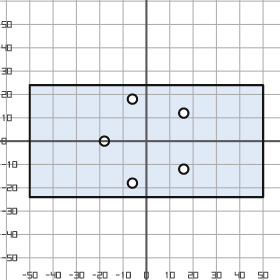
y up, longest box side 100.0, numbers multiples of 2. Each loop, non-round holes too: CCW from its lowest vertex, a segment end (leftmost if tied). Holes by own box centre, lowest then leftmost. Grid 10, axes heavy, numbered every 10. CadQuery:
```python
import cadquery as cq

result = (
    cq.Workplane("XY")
    .moveTo(-50.0, -24.0)
    .lineTo(50.0, -24.0)
    .lineTo(50.0, 24.0)
    .lineTo(-50.0, 24.0)
    .close()
    .moveTo(-6.0, -18.0)
    .circle(2.0)
    .moveTo(16.0, -12.0)
    .circle(2.0)
    .moveTo(-18.0, 0.0)
    .circle(2.0)
    .moveTo(16.0, 12.0)
    .circle(2.0)
    .moveTo(-6.0, 18.0)
    .circle(2.0)
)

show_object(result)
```